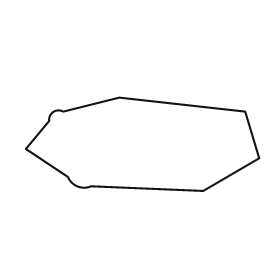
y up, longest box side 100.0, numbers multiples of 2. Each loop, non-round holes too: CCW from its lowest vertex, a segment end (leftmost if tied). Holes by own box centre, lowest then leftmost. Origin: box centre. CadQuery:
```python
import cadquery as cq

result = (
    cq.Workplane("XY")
    .moveTo(26.0, -20.0)
    .lineTo(50.0, -6.0)
    .lineTo(44.0, 14.0)
    .lineTo(-10.0, 20.0)
    .lineTo(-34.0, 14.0)
    .threePointArc((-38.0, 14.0), (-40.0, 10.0))
    .lineTo(-50.0, -2.0)
    .lineTo(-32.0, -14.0)
    .threePointArc((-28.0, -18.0), (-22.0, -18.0))
    .close()
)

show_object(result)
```